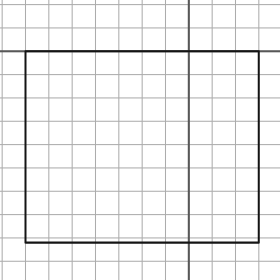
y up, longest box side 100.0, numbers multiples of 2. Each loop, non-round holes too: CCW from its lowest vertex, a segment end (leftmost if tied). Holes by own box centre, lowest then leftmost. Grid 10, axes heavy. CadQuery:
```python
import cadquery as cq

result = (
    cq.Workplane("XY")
    .moveTo(-70.0, -82.0)
    .lineTo(30.0, -82.0)
    .lineTo(30.0, 0.0)
    .lineTo(-70.0, 0.0)
    .close()
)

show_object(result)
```